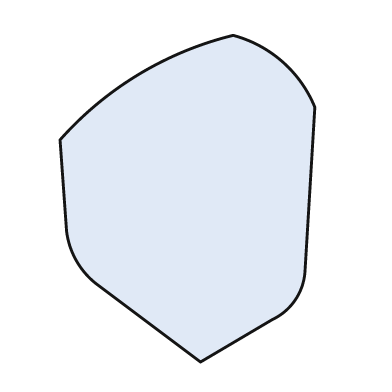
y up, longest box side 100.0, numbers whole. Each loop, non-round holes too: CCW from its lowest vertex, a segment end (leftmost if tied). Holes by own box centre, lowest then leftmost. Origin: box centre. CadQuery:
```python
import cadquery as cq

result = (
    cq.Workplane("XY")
    .moveTo(4.0, -50.0)
    .lineTo(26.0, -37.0)
    .threePointArc((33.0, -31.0), (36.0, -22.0))
    .lineTo(39.0, 28.0)
    .threePointArc((29.0, 42.0), (14.0, 50.0))
    .threePointArc((-15.0, 38.0), (-39.0, 18.0))
    .lineTo(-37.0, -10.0)
    .threePointArc((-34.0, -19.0), (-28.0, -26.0))
    .close()
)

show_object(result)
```